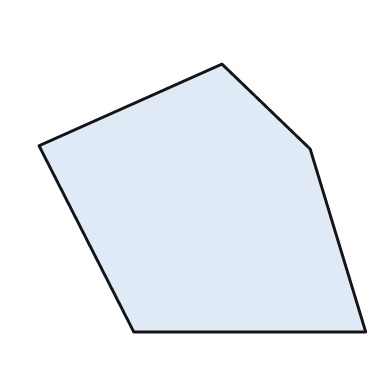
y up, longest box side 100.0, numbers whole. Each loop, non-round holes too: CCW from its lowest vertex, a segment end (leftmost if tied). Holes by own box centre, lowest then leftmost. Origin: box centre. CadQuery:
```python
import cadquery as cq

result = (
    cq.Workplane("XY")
    .moveTo(-21.0, -41.0)
    .lineTo(50.0, -41.0)
    .lineTo(33.0, 15.0)
    .lineTo(6.0, 41.0)
    .lineTo(-50.0, 16.0)
    .close()
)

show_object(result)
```